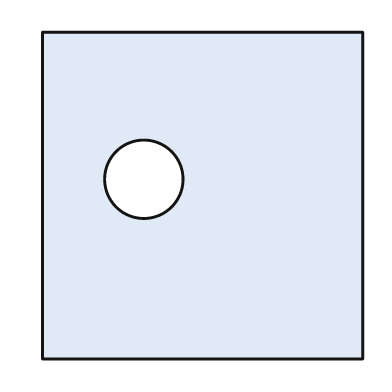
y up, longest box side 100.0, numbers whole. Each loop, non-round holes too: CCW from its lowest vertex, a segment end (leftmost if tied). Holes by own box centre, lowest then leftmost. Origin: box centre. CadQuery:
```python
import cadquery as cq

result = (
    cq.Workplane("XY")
    .moveTo(-49.0, -50.0)
    .lineTo(49.0, -50.0)
    .lineTo(49.0, 50.0)
    .lineTo(-49.0, 50.0)
    .close()
    .moveTo(-18.0, 5.0)
    .circle(12.0)
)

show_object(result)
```